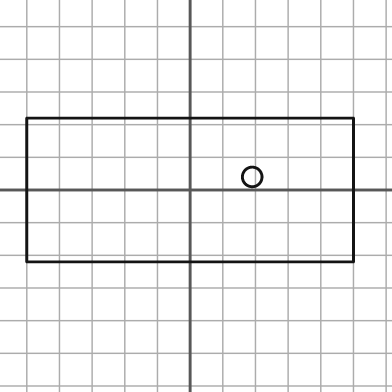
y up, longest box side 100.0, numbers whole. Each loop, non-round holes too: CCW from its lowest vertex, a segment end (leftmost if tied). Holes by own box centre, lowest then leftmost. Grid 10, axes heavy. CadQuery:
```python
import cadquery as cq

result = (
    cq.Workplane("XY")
    .moveTo(-50.0, -22.0)
    .lineTo(50.0, -22.0)
    .lineTo(50.0, 22.0)
    .lineTo(-50.0, 22.0)
    .close()
    .moveTo(19.0, 4.0)
    .circle(3.0)
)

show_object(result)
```